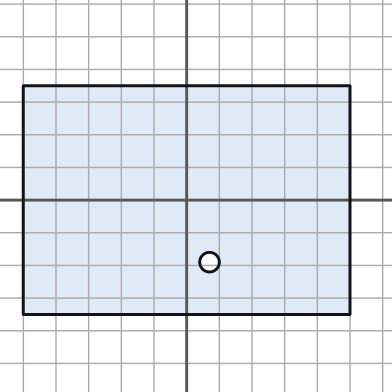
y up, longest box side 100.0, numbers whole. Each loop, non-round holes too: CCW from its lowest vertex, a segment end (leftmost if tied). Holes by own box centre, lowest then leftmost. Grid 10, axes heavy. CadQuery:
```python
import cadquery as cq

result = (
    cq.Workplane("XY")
    .moveTo(-50.0, -35.0)
    .lineTo(50.0, -35.0)
    .lineTo(50.0, 35.0)
    .lineTo(-50.0, 35.0)
    .close()
    .moveTo(7.0, -19.0)
    .circle(3.0)
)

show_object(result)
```